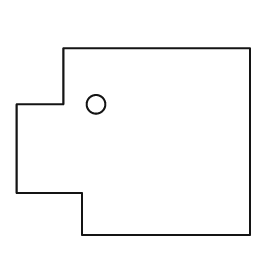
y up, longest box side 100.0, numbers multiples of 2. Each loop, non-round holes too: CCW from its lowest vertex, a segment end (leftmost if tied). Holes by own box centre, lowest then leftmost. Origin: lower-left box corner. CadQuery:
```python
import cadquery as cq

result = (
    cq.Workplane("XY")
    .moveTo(28.0, 0.0)
    .lineTo(100.0, 0.0)
    .lineTo(100.0, 80.0)
    .lineTo(20.0, 80.0)
    .lineTo(20.0, 56.0)
    .lineTo(0.0, 56.0)
    .lineTo(0.0, 18.0)
    .lineTo(28.0, 18.0)
    .close()
    .moveTo(34.0, 56.0)
    .circle(4.0)
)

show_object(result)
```